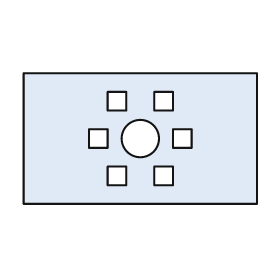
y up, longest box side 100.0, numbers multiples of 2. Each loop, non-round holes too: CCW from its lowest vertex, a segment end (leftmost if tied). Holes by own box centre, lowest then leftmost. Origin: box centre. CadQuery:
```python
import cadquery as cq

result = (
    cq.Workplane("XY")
    .moveTo(-50.0, -28.0)
    .lineTo(50.0, -28.0)
    .lineTo(50.0, 28.0)
    .lineTo(-50.0, 28.0)
    .close()
    .moveTo(-14.0, -20.0)
    .lineTo(-6.0, -20.0)
    .lineTo(-6.0, -12.0)
    .lineTo(-14.0, -12.0)
    .close()
    .moveTo(6.0, -20.0)
    .lineTo(14.0, -20.0)
    .lineTo(14.0, -12.0)
    .lineTo(6.0, -12.0)
    .close()
    .moveTo(-22.0, -4.0)
    .lineTo(-14.0, -4.0)
    .lineTo(-14.0, 4.0)
    .lineTo(-22.0, 4.0)
    .close()
    .moveTo(0.0, 0.0)
    .circle(8.0)
    .moveTo(14.0, -4.0)
    .lineTo(22.0, -4.0)
    .lineTo(22.0, 4.0)
    .lineTo(14.0, 4.0)
    .close()
    .moveTo(-14.0, 12.0)
    .lineTo(-6.0, 12.0)
    .lineTo(-6.0, 20.0)
    .lineTo(-14.0, 20.0)
    .close()
    .moveTo(6.0, 12.0)
    .lineTo(14.0, 12.0)
    .lineTo(14.0, 20.0)
    .lineTo(6.0, 20.0)
    .close()
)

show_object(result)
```